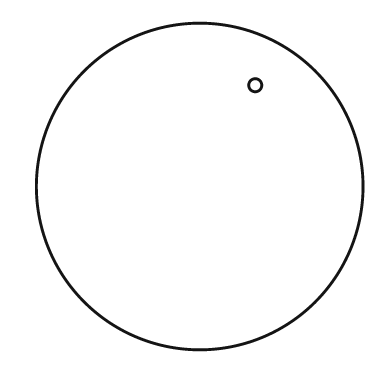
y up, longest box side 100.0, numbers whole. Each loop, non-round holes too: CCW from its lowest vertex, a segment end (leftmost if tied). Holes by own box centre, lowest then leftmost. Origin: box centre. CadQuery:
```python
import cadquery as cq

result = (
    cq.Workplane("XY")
    .moveTo(0.0, 0.0)
    .circle(50.0)
    .moveTo(17.0, 31.0)
    .circle(2.0)
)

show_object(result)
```